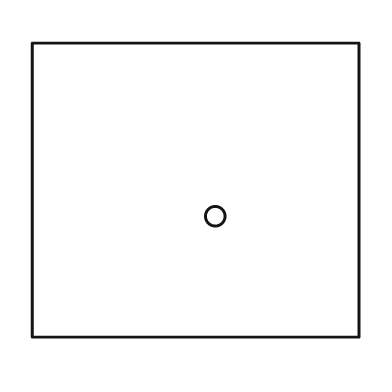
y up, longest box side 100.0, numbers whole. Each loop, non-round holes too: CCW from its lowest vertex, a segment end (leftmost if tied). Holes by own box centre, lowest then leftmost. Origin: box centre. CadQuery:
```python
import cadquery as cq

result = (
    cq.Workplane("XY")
    .moveTo(-50.0, -45.0)
    .lineTo(50.0, -45.0)
    .lineTo(50.0, 45.0)
    .lineTo(-50.0, 45.0)
    .close()
    .moveTo(6.0, -8.0)
    .circle(3.0)
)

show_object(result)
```